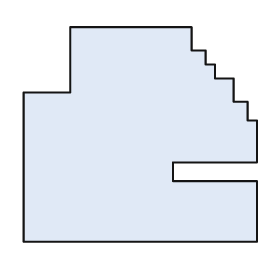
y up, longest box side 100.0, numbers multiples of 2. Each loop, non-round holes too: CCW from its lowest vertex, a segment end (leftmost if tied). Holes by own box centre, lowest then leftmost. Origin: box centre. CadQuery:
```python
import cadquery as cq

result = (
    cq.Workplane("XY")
    .moveTo(-50.0, -46.0)
    .lineTo(50.0, -46.0)
    .lineTo(50.0, -20.0)
    .lineTo(14.0, -20.0)
    .lineTo(14.0, -12.0)
    .lineTo(50.0, -12.0)
    .lineTo(50.0, 6.0)
    .lineTo(46.0, 6.0)
    .lineTo(46.0, 14.0)
    .lineTo(40.0, 14.0)
    .lineTo(40.0, 24.0)
    .lineTo(32.0, 24.0)
    .lineTo(32.0, 30.0)
    .lineTo(28.0, 30.0)
    .lineTo(28.0, 36.0)
    .lineTo(22.0, 36.0)
    .lineTo(22.0, 46.0)
    .lineTo(-30.0, 46.0)
    .lineTo(-30.0, 18.0)
    .lineTo(-50.0, 18.0)
    .close()
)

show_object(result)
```